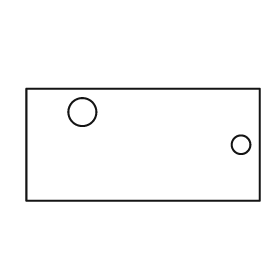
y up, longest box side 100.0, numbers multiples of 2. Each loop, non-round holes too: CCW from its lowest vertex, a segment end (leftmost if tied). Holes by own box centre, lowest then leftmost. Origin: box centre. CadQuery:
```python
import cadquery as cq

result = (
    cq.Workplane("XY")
    .moveTo(-50.0, -24.0)
    .lineTo(50.0, -24.0)
    .lineTo(50.0, 24.0)
    .lineTo(-50.0, 24.0)
    .close()
    .moveTo(42.0, 0.0)
    .circle(4.0)
    .moveTo(-26.0, 14.0)
    .circle(6.0)
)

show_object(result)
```